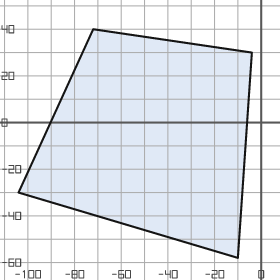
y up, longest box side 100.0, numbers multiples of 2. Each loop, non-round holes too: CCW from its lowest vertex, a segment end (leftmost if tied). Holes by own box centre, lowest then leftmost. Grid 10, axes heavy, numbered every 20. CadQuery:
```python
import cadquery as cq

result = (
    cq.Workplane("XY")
    .moveTo(-10.0, -58.0)
    .lineTo(-4.0, 30.0)
    .lineTo(-72.0, 40.0)
    .lineTo(-104.0, -30.0)
    .close()
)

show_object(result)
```